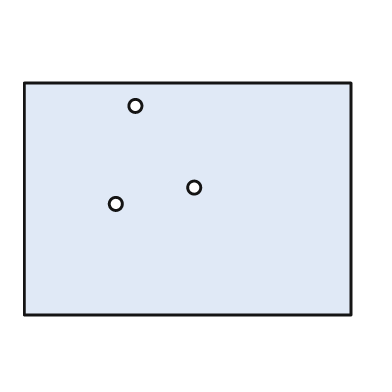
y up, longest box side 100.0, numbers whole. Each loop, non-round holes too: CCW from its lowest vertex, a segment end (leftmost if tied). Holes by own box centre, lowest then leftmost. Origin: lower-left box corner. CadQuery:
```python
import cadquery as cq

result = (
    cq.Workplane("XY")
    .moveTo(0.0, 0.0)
    .lineTo(100.0, 0.0)
    .lineTo(100.0, 71.0)
    .lineTo(0.0, 71.0)
    .close()
    .moveTo(28.0, 34.0)
    .circle(2.0)
    .moveTo(52.0, 39.0)
    .circle(2.0)
    .moveTo(34.0, 64.0)
    .circle(2.0)
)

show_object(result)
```